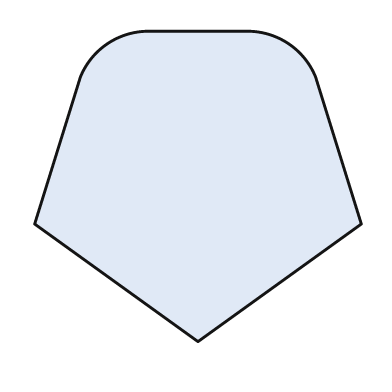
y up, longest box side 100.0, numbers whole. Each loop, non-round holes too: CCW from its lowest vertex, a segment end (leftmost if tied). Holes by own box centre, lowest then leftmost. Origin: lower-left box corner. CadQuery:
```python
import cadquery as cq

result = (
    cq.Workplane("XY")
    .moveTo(50.0, 0.0)
    .lineTo(100.0, 36.0)
    .lineTo(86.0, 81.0)
    .threePointArc((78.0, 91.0), (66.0, 95.0))
    .lineTo(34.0, 95.0)
    .threePointArc((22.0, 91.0), (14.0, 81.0))
    .lineTo(0.0, 36.0)
    .close()
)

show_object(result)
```